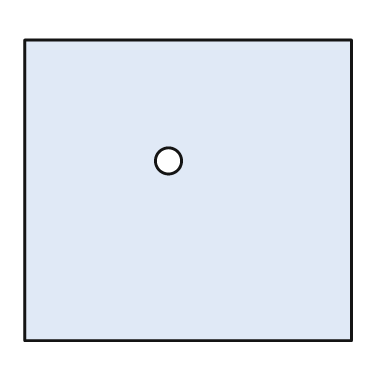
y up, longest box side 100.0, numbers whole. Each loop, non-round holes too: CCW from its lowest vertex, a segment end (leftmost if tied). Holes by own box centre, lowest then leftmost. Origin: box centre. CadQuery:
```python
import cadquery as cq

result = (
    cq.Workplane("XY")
    .moveTo(-50.0, -46.0)
    .lineTo(50.0, -46.0)
    .lineTo(50.0, 46.0)
    .lineTo(-50.0, 46.0)
    .close()
    .moveTo(-6.0, 9.0)
    .circle(4.0)
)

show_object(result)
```